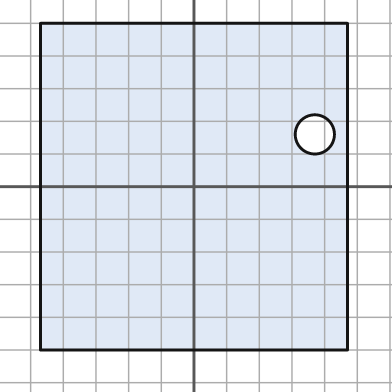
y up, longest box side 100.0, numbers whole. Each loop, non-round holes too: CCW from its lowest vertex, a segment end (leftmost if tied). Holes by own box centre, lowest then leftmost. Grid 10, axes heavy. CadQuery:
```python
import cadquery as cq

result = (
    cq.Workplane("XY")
    .moveTo(-47.0, -50.0)
    .lineTo(47.0, -50.0)
    .lineTo(47.0, 50.0)
    .lineTo(-47.0, 50.0)
    .close()
    .moveTo(37.0, 16.0)
    .circle(6.0)
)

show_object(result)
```